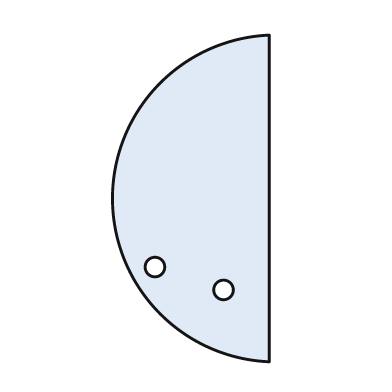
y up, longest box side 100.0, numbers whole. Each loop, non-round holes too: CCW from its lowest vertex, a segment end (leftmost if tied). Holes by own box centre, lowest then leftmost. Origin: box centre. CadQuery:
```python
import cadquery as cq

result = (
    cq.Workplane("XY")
    .moveTo(24.0, -50.0)
    .lineTo(24.0, 50.0)
    .threePointArc((-24.0, 0.0), (24.0, -50.0))
    .close()
    .moveTo(10.0, -28.0)
    .circle(3.0)
    .moveTo(-11.0, -21.0)
    .circle(3.0)
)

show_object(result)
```